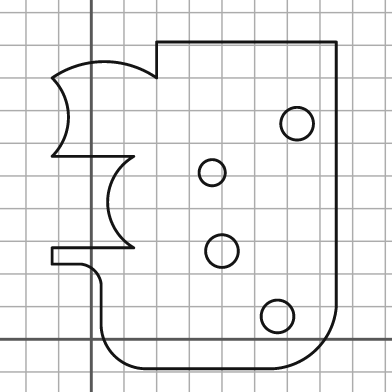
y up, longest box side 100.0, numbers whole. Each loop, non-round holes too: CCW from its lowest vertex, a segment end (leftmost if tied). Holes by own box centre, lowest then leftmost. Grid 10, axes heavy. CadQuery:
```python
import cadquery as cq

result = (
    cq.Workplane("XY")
    .moveTo(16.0, -9.0)
    .lineTo(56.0, -9.0)
    .threePointArc((69.0, -3.0), (75.0, 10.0))
    .lineTo(75.0, 91.0)
    .lineTo(20.0, 91.0)
    .lineTo(20.0, 80.0)
    .threePointArc((4.0, 85.0), (-12.0, 80.0))
    .threePointArc((-7.0, 68.0), (-12.0, 56.0))
    .lineTo(13.0, 56.0)
    .threePointArc((5.0, 42.0), (13.0, 28.0))
    .lineTo(-12.0, 28.0)
    .lineTo(-12.0, 23.0)
    .lineTo(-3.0, 23.0)
    .threePointArc((1.0, 21.0), (3.0, 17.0))
    .lineTo(3.0, 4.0)
    .threePointArc((7.0, -5.0), (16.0, -9.0))
    .close()
    .moveTo(57.0, 7.0)
    .circle(5.0)
    .moveTo(40.0, 27.0)
    .circle(5.0)
    .moveTo(37.0, 51.0)
    .circle(4.0)
    .moveTo(63.0, 66.0)
    .circle(5.0)
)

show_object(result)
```